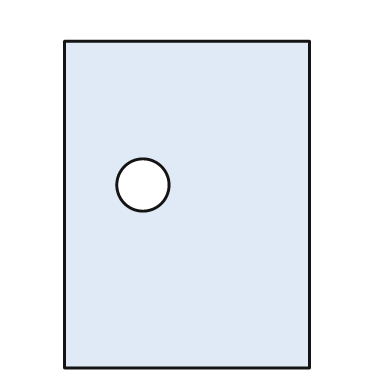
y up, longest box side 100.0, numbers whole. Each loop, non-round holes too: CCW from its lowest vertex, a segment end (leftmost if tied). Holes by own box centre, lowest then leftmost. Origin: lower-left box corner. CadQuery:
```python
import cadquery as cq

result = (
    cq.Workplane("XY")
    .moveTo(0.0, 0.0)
    .lineTo(75.0, 0.0)
    .lineTo(75.0, 100.0)
    .lineTo(0.0, 100.0)
    .close()
    .moveTo(24.0, 56.0)
    .circle(8.0)
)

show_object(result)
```